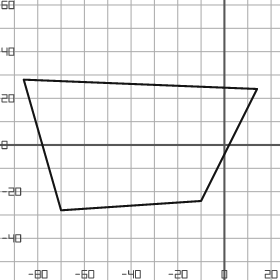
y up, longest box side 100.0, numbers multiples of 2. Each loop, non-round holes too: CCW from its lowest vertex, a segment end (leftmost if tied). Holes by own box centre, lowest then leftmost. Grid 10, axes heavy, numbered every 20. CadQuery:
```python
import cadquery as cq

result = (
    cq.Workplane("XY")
    .moveTo(-70.0, -28.0)
    .lineTo(-10.0, -24.0)
    .lineTo(14.0, 24.0)
    .lineTo(-86.0, 28.0)
    .close()
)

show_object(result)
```